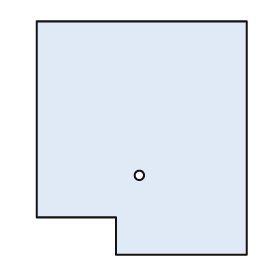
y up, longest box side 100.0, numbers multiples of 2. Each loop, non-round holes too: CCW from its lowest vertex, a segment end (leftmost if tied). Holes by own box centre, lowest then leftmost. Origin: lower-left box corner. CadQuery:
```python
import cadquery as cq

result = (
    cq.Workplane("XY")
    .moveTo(34.0, 0.0)
    .lineTo(90.0, 0.0)
    .lineTo(90.0, 100.0)
    .lineTo(0.0, 100.0)
    .lineTo(0.0, 16.0)
    .lineTo(34.0, 16.0)
    .close()
    .moveTo(44.0, 34.0)
    .circle(2.0)
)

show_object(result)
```